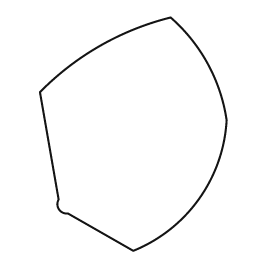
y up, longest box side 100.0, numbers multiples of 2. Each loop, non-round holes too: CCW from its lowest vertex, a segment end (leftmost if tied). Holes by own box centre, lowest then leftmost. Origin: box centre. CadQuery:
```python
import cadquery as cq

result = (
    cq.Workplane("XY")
    .moveTo(0.0, -50.0)
    .threePointArc((28.0, -28.0), (40.0, 6.0))
    .threePointArc((32.0, 30.0), (16.0, 50.0))
    .threePointArc((-14.0, 38.0), (-40.0, 18.0))
    .lineTo(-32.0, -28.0)
    .threePointArc((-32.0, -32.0), (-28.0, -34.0))
    .close()
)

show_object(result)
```